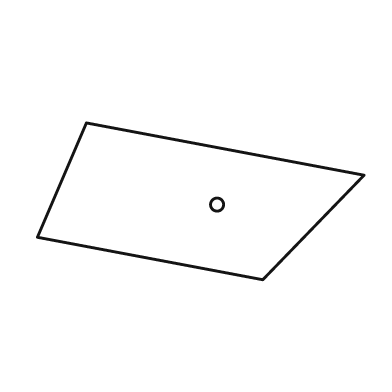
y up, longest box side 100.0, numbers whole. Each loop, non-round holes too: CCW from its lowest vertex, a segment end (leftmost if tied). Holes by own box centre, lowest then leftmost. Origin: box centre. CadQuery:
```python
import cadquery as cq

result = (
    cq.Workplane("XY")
    .moveTo(19.0, -24.0)
    .lineTo(50.0, 8.0)
    .lineTo(-35.0, 24.0)
    .lineTo(-50.0, -11.0)
    .close()
    .moveTo(5.0, -1.0)
    .circle(2.0)
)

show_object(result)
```